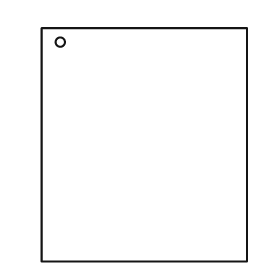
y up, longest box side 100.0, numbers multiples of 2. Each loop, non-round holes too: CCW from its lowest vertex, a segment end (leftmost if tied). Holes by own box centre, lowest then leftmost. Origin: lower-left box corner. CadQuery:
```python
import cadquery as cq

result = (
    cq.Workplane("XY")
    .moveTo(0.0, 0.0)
    .lineTo(88.0, 0.0)
    .lineTo(88.0, 100.0)
    .lineTo(0.0, 100.0)
    .close()
    .moveTo(8.0, 94.0)
    .circle(2.0)
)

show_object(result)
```